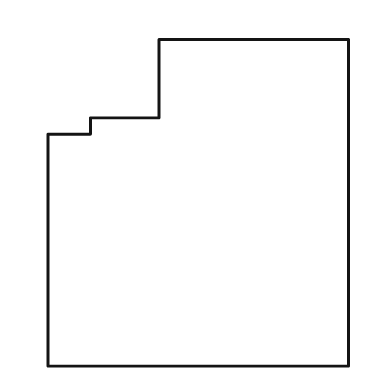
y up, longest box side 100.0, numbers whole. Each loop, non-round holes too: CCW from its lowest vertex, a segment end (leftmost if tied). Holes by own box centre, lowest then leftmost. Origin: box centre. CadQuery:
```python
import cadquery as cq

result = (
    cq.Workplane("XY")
    .moveTo(-46.0, -50.0)
    .lineTo(46.0, -50.0)
    .lineTo(46.0, 50.0)
    .lineTo(-12.0, 50.0)
    .lineTo(-12.0, 26.0)
    .lineTo(-33.0, 26.0)
    .lineTo(-33.0, 21.0)
    .lineTo(-46.0, 21.0)
    .close()
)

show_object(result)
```